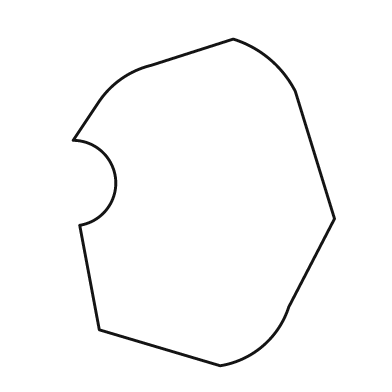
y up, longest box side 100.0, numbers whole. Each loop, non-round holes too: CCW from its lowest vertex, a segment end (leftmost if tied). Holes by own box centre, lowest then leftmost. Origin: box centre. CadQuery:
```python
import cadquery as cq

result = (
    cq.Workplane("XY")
    .moveTo(5.0, -50.0)
    .threePointArc((18.0, -44.0), (26.0, -32.0))
    .lineTo(40.0, -5.0)
    .lineTo(28.0, 34.0)
    .threePointArc((20.0, 44.0), (9.0, 50.0))
    .lineTo(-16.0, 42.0)
    .threePointArc((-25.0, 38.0), (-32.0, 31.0))
    .lineTo(-40.0, 19.0)
    .threePointArc((-27.0, 7.0), (-38.0, -7.0))
    .lineTo(-32.0, -39.0)
    .close()
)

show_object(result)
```